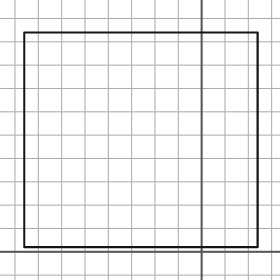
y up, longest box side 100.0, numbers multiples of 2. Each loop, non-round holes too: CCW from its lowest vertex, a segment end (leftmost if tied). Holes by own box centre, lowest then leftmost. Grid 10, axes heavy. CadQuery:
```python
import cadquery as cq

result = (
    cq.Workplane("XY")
    .moveTo(-76.0, 2.0)
    .lineTo(24.0, 2.0)
    .lineTo(24.0, 94.0)
    .lineTo(-76.0, 94.0)
    .close()
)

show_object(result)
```